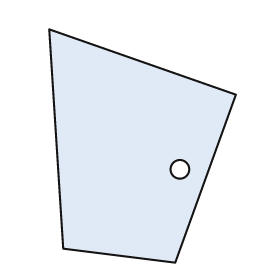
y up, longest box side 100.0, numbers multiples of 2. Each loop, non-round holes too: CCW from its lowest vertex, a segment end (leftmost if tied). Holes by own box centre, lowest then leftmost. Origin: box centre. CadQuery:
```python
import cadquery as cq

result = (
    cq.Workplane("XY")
    .moveTo(14.0, -50.0)
    .lineTo(40.0, 22.0)
    .lineTo(-40.0, 50.0)
    .lineTo(-34.0, -44.0)
    .close()
    .moveTo(16.0, -10.0)
    .circle(4.0)
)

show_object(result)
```